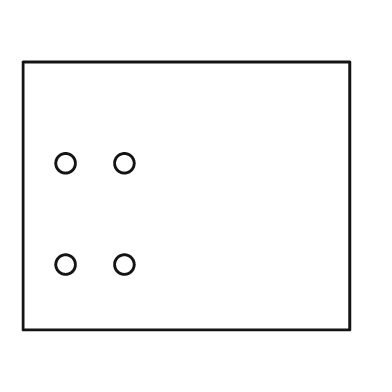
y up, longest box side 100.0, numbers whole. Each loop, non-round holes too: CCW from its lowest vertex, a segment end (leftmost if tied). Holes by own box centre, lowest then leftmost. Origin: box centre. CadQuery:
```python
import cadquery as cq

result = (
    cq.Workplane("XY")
    .moveTo(-50.0, -41.0)
    .lineTo(50.0, -41.0)
    .lineTo(50.0, 41.0)
    .lineTo(-50.0, 41.0)
    .close()
    .moveTo(-37.0, -21.0)
    .circle(3.0)
    .moveTo(-19.0, -21.0)
    .circle(3.0)
    .moveTo(-37.0, 10.0)
    .circle(3.0)
    .moveTo(-19.0, 10.0)
    .circle(3.0)
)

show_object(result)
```